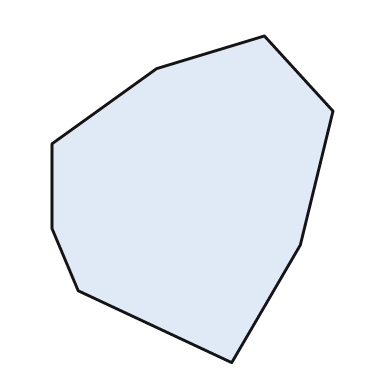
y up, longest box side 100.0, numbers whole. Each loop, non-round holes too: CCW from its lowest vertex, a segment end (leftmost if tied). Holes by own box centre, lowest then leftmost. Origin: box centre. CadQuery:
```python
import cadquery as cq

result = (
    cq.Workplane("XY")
    .moveTo(12.0, -50.0)
    .lineTo(33.0, -14.0)
    .lineTo(43.0, 27.0)
    .lineTo(22.0, 50.0)
    .lineTo(-11.0, 40.0)
    .lineTo(-43.0, 17.0)
    .lineTo(-43.0, -9.0)
    .lineTo(-35.0, -28.0)
    .close()
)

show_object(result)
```